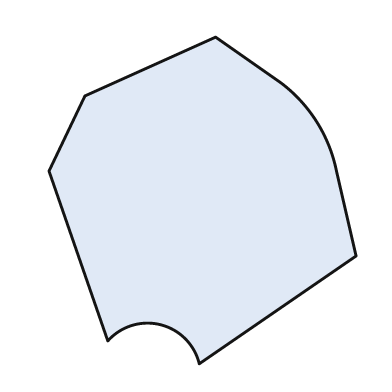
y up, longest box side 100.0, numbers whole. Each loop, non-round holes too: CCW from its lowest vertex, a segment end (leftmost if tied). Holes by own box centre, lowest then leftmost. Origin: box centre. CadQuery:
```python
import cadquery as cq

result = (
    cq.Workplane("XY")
    .moveTo(-1.0, -50.0)
    .lineTo(47.0, -17.0)
    .lineTo(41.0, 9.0)
    .threePointArc((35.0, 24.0), (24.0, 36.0))
    .lineTo(4.0, 50.0)
    .lineTo(-36.0, 32.0)
    .lineTo(-47.0, 9.0)
    .lineTo(-29.0, -43.0)
    .threePointArc((-13.0, -38.0), (-1.0, -50.0))
    .close()
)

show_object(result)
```